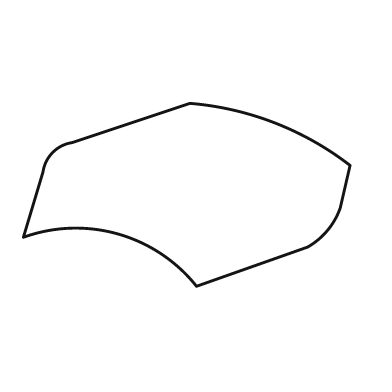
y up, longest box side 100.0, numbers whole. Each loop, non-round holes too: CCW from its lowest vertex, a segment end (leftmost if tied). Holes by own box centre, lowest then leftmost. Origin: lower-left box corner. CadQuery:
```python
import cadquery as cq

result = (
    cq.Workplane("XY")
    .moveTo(53.0, 0.0)
    .lineTo(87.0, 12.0)
    .threePointArc((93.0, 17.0), (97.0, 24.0))
    .lineTo(100.0, 37.0)
    .threePointArc((77.0, 50.0), (51.0, 56.0))
    .lineTo(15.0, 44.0)
    .threePointArc((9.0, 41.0), (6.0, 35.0))
    .lineTo(0.0, 15.0)
    .threePointArc((29.0, 16.0), (53.0, 0.0))
    .close()
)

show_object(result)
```